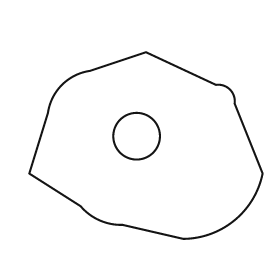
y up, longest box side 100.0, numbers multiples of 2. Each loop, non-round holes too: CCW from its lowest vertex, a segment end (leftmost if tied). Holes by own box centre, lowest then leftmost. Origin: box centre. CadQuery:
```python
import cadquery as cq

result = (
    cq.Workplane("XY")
    .moveTo(16.0, -40.0)
    .threePointArc((38.0, -32.0), (50.0, -12.0))
    .lineTo(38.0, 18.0)
    .threePointArc((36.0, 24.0), (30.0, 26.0))
    .lineTo(0.0, 40.0)
    .lineTo(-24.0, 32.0)
    .threePointArc((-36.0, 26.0), (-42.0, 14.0))
    .lineTo(-50.0, -12.0)
    .lineTo(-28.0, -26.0)
    .threePointArc((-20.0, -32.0), (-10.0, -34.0))
    .close()
    .moveTo(-4.0, 4.0)
    .circle(10.0)
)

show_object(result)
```